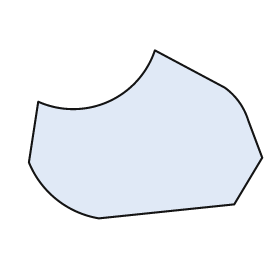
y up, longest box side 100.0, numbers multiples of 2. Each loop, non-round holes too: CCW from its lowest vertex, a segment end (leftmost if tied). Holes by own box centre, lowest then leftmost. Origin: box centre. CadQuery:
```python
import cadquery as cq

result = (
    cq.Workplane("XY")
    .moveTo(-20.0, -36.0)
    .lineTo(38.0, -30.0)
    .lineTo(50.0, -10.0)
    .lineTo(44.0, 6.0)
    .threePointArc((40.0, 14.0), (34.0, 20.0))
    .lineTo(4.0, 36.0)
    .threePointArc((-16.0, 14.0), (-46.0, 14.0))
    .lineTo(-50.0, -12.0)
    .threePointArc((-38.0, -28.0), (-20.0, -36.0))
    .close()
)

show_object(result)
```